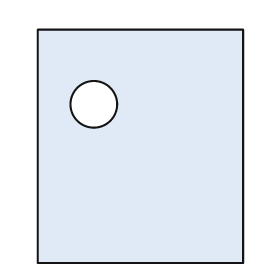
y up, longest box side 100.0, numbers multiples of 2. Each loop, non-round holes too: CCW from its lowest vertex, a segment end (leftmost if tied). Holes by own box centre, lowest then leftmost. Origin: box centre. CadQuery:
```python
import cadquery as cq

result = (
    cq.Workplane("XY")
    .moveTo(-44.0, -50.0)
    .lineTo(44.0, -50.0)
    .lineTo(44.0, 50.0)
    .lineTo(-44.0, 50.0)
    .close()
    .moveTo(-20.0, 18.0)
    .circle(10.0)
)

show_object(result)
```